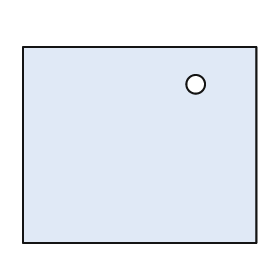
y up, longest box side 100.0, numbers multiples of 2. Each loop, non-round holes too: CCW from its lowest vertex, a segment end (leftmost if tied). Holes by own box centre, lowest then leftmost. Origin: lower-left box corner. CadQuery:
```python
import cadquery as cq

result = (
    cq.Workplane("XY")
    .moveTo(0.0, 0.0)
    .lineTo(100.0, 0.0)
    .lineTo(100.0, 84.0)
    .lineTo(0.0, 84.0)
    .close()
    .moveTo(74.0, 68.0)
    .circle(4.0)
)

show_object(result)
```